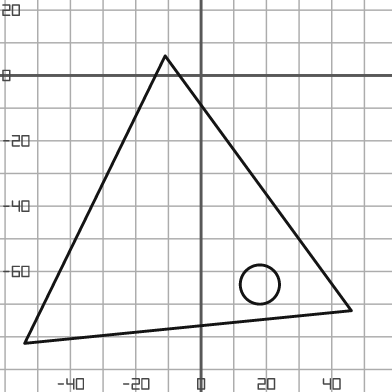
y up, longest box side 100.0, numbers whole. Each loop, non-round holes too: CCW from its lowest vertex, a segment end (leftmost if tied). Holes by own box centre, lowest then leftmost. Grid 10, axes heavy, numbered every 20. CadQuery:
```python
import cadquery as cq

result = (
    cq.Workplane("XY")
    .moveTo(-54.0, -82.0)
    .lineTo(46.0, -72.0)
    .lineTo(-11.0, 6.0)
    .close()
    .moveTo(18.0, -64.0)
    .circle(6.0)
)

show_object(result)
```